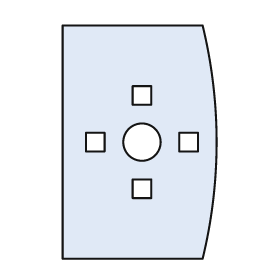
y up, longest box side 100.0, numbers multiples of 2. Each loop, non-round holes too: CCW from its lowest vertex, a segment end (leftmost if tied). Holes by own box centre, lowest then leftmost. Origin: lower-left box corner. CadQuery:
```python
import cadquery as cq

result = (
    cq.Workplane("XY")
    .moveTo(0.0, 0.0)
    .lineTo(60.0, 0.0)
    .threePointArc((66.0, 50.0), (60.0, 100.0))
    .lineTo(0.0, 100.0)
    .close()
    .moveTo(30.0, 26.0)
    .lineTo(38.0, 26.0)
    .lineTo(38.0, 34.0)
    .lineTo(30.0, 34.0)
    .close()
    .moveTo(10.0, 46.0)
    .lineTo(18.0, 46.0)
    .lineTo(18.0, 54.0)
    .lineTo(10.0, 54.0)
    .close()
    .moveTo(34.0, 50.0)
    .circle(8.0)
    .moveTo(50.0, 46.0)
    .lineTo(58.0, 46.0)
    .lineTo(58.0, 54.0)
    .lineTo(50.0, 54.0)
    .close()
    .moveTo(30.0, 66.0)
    .lineTo(38.0, 66.0)
    .lineTo(38.0, 74.0)
    .lineTo(30.0, 74.0)
    .close()
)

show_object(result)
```